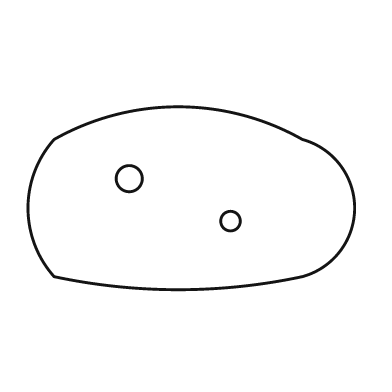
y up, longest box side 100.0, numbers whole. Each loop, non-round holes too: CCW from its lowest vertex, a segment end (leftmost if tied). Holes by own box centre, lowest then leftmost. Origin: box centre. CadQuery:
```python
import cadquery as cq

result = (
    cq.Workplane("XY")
    .moveTo(-42.0, -24.0)
    .threePointArc((-4.0, -28.0), (34.0, -24.0))
    .threePointArc((50.0, -3.0), (34.0, 18.0))
    .threePointArc((-4.0, 28.0), (-42.0, 18.0))
    .threePointArc((-50.0, -3.0), (-42.0, -24.0))
    .close()
    .moveTo(12.0, -7.0)
    .circle(3.0)
    .moveTo(-19.0, 6.0)
    .circle(4.0)
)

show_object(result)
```